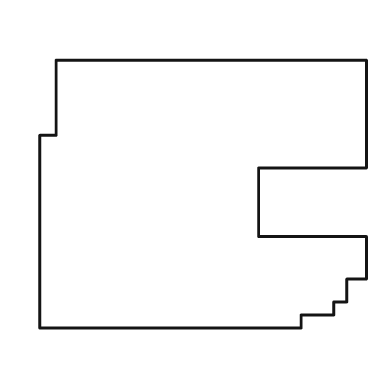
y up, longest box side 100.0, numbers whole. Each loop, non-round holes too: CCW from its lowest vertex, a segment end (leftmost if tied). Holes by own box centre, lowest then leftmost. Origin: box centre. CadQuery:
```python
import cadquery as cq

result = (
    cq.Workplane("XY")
    .moveTo(-50.0, -41.0)
    .lineTo(30.0, -41.0)
    .lineTo(30.0, -37.0)
    .lineTo(40.0, -37.0)
    .lineTo(40.0, -33.0)
    .lineTo(44.0, -33.0)
    .lineTo(44.0, -26.0)
    .lineTo(50.0, -26.0)
    .lineTo(50.0, -13.0)
    .lineTo(17.0, -13.0)
    .lineTo(17.0, 8.0)
    .lineTo(50.0, 8.0)
    .lineTo(50.0, 41.0)
    .lineTo(-45.0, 41.0)
    .lineTo(-45.0, 18.0)
    .lineTo(-50.0, 18.0)
    .close()
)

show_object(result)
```